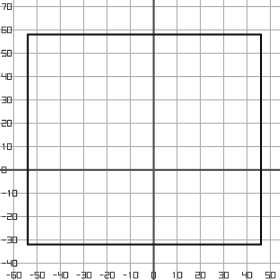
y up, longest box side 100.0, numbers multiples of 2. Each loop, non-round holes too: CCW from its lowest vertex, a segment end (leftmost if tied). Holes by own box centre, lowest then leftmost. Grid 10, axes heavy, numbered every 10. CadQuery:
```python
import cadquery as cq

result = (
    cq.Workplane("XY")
    .moveTo(-54.0, -32.0)
    .lineTo(46.0, -32.0)
    .lineTo(46.0, 58.0)
    .lineTo(-54.0, 58.0)
    .close()
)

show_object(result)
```